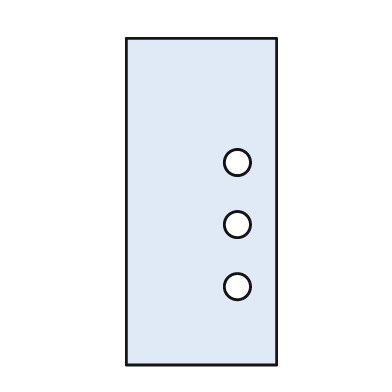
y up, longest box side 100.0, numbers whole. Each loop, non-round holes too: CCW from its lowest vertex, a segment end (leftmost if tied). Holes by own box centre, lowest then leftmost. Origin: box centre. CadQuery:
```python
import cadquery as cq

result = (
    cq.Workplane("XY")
    .moveTo(-23.0, -50.0)
    .lineTo(23.0, -50.0)
    .lineTo(23.0, 50.0)
    .lineTo(-23.0, 50.0)
    .close()
    .moveTo(11.0, -26.0)
    .circle(4.0)
    .moveTo(11.0, -7.0)
    .circle(4.0)
    .moveTo(11.0, 12.0)
    .circle(4.0)
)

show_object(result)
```